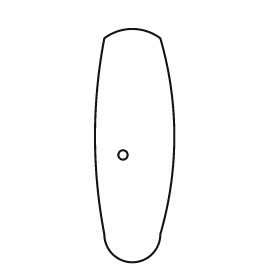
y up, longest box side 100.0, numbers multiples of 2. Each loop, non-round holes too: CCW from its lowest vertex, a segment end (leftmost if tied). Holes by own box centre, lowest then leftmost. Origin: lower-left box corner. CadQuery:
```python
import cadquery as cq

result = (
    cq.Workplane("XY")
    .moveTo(4.0, 12.0)
    .threePointArc((16.0, 0.0), (28.0, 12.0))
    .threePointArc((34.0, 54.0), (28.0, 96.0))
    .threePointArc((16.0, 100.0), (4.0, 96.0))
    .threePointArc((0.0, 54.0), (4.0, 12.0))
    .close()
    .moveTo(12.0, 46.0)
    .circle(2.0)
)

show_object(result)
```